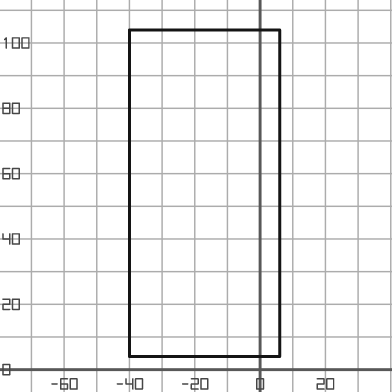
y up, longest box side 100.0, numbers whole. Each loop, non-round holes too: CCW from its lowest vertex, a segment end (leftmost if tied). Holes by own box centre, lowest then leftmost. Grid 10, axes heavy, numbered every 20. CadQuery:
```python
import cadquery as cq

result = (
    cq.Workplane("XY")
    .moveTo(-40.0, 4.0)
    .lineTo(6.0, 4.0)
    .lineTo(6.0, 104.0)
    .lineTo(-40.0, 104.0)
    .close()
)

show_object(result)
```